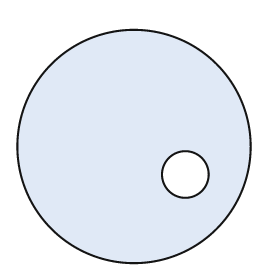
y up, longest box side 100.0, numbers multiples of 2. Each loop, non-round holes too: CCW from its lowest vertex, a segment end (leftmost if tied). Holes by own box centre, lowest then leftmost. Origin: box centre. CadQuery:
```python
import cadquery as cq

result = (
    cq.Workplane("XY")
    .moveTo(0.0, 0.0)
    .circle(50.0)
    .moveTo(22.0, -12.0)
    .circle(10.0)
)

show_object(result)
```